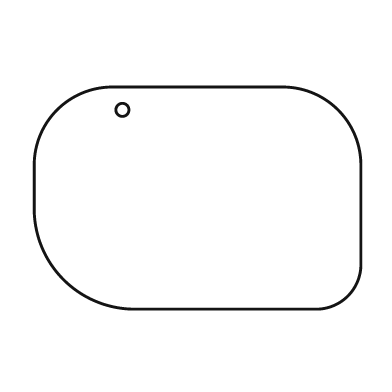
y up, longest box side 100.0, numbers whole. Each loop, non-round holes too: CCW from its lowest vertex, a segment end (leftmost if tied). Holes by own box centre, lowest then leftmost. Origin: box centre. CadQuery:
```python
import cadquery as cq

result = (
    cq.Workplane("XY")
    .moveTo(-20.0, -34.0)
    .lineTo(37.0, -34.0)
    .threePointArc((46.0, -30.0), (50.0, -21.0))
    .lineTo(50.0, 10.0)
    .threePointArc((43.0, 27.0), (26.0, 34.0))
    .lineTo(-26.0, 34.0)
    .threePointArc((-43.0, 27.0), (-50.0, 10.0))
    .lineTo(-50.0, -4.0)
    .threePointArc((-41.0, -25.0), (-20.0, -34.0))
    .close()
    .moveTo(-23.0, 27.0)
    .circle(2.0)
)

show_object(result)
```